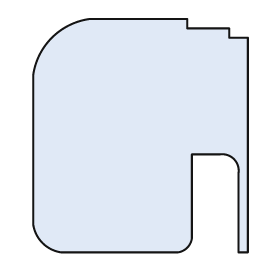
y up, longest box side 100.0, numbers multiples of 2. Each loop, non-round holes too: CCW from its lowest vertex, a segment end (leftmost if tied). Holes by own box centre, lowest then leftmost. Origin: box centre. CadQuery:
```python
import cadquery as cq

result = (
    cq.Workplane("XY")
    .moveTo(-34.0, -50.0)
    .lineTo(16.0, -50.0)
    .threePointArc((20.0, -48.0), (22.0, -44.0))
    .lineTo(22.0, -8.0)
    .lineTo(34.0, -8.0)
    .threePointArc((40.0, -10.0), (42.0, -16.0))
    .lineTo(42.0, -50.0)
    .lineTo(46.0, -50.0)
    .lineTo(46.0, 42.0)
    .lineTo(38.0, 42.0)
    .lineTo(38.0, 46.0)
    .lineTo(20.0, 46.0)
    .lineTo(20.0, 50.0)
    .lineTo(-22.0, 50.0)
    .threePointArc((-38.0, 42.0), (-46.0, 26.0))
    .lineTo(-46.0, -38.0)
    .threePointArc((-42.0, -46.0), (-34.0, -50.0))
    .close()
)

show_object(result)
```